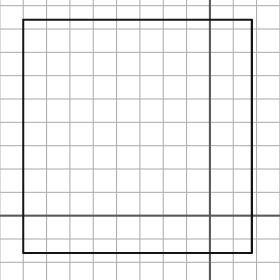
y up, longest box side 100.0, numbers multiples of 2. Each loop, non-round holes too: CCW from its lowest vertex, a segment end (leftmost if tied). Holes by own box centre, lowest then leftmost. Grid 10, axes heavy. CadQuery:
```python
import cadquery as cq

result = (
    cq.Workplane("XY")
    .moveTo(-80.0, -16.0)
    .lineTo(18.0, -16.0)
    .lineTo(18.0, 84.0)
    .lineTo(-80.0, 84.0)
    .close()
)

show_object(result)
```